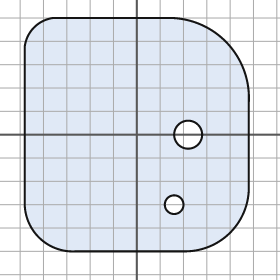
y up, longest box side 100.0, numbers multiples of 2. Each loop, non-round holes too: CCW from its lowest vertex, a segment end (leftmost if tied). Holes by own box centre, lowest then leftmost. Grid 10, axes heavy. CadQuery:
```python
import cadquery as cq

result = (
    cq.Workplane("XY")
    .moveTo(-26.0, -50.0)
    .lineTo(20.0, -50.0)
    .threePointArc((40.0, -42.0), (48.0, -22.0))
    .lineTo(48.0, 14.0)
    .threePointArc((38.0, 40.0), (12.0, 50.0))
    .lineTo(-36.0, 50.0)
    .threePointArc((-44.0, 46.0), (-48.0, 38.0))
    .lineTo(-48.0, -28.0)
    .threePointArc((-42.0, -44.0), (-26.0, -50.0))
    .close()
    .moveTo(16.0, -30.0)
    .circle(4.0)
    .moveTo(22.0, 0.0)
    .circle(6.0)
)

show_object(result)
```